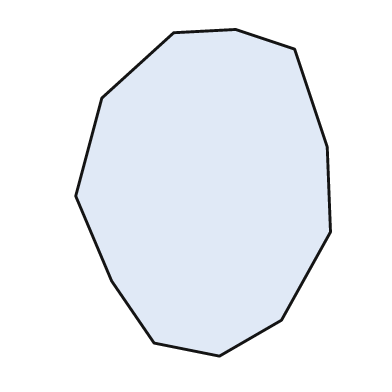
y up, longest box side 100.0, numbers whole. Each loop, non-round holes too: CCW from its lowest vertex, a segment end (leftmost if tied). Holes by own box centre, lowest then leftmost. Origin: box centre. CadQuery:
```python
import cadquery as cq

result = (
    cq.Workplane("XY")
    .moveTo(5.0, -50.0)
    .lineTo(24.0, -39.0)
    .lineTo(39.0, -12.0)
    .lineTo(38.0, 14.0)
    .lineTo(28.0, 44.0)
    .lineTo(10.0, 50.0)
    .lineTo(-9.0, 49.0)
    .lineTo(-31.0, 29.0)
    .lineTo(-39.0, -1.0)
    .lineTo(-28.0, -27.0)
    .lineTo(-15.0, -46.0)
    .close()
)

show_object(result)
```